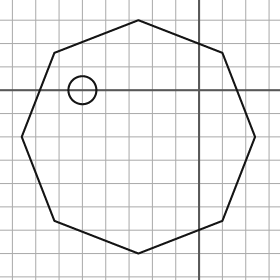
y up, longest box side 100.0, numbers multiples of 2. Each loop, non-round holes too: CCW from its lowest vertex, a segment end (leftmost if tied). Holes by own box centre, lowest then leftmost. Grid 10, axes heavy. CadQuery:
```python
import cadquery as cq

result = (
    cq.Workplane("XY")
    .moveTo(-26.0, -70.0)
    .lineTo(10.0, -56.0)
    .lineTo(24.0, -20.0)
    .lineTo(10.0, 16.0)
    .lineTo(-26.0, 30.0)
    .lineTo(-62.0, 16.0)
    .lineTo(-76.0, -20.0)
    .lineTo(-62.0, -56.0)
    .close()
    .moveTo(-50.0, 0.0)
    .circle(6.0)
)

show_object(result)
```